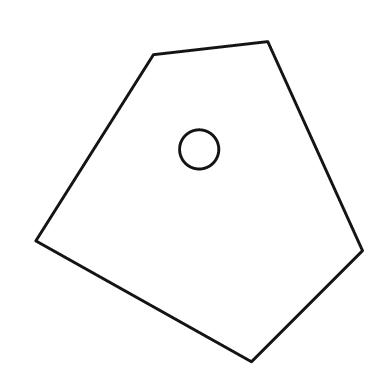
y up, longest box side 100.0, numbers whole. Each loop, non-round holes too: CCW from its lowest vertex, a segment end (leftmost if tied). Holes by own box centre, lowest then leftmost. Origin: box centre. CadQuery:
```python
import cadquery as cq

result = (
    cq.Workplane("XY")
    .moveTo(16.0, -49.0)
    .lineTo(50.0, -15.0)
    .lineTo(21.0, 49.0)
    .lineTo(-14.0, 45.0)
    .lineTo(-50.0, -12.0)
    .close()
    .moveTo(0.0, 16.0)
    .circle(6.0)
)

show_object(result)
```